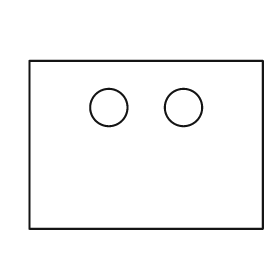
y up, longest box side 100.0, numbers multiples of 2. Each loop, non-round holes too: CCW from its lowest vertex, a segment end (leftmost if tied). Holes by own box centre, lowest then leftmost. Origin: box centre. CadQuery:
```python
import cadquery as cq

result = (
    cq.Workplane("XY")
    .moveTo(-50.0, -36.0)
    .lineTo(50.0, -36.0)
    .lineTo(50.0, 36.0)
    .lineTo(-50.0, 36.0)
    .close()
    .moveTo(-16.0, 16.0)
    .circle(8.0)
    .moveTo(16.0, 16.0)
    .circle(8.0)
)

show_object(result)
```